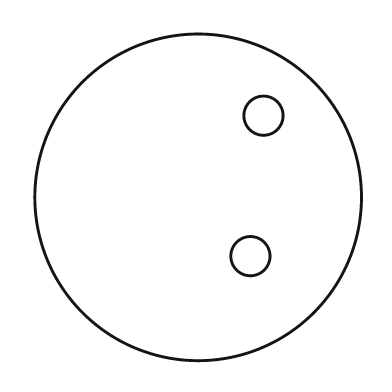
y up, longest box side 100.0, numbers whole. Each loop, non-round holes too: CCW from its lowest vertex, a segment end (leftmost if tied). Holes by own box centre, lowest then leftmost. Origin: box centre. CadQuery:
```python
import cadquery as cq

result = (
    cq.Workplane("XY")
    .moveTo(0.0, 0.0)
    .circle(50.0)
    .moveTo(16.0, -18.0)
    .circle(6.0)
    .moveTo(20.0, 25.0)
    .circle(6.0)
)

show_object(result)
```